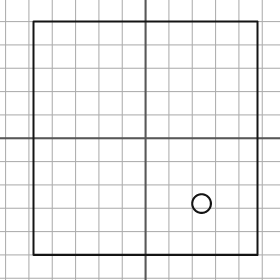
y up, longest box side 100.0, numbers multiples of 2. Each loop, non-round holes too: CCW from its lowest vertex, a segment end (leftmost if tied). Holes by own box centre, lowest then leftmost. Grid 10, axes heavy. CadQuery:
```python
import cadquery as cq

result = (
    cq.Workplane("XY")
    .moveTo(-48.0, -50.0)
    .lineTo(48.0, -50.0)
    .lineTo(48.0, 50.0)
    .lineTo(-48.0, 50.0)
    .close()
    .moveTo(24.0, -28.0)
    .circle(4.0)
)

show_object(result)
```